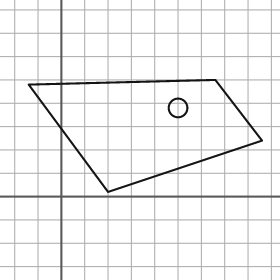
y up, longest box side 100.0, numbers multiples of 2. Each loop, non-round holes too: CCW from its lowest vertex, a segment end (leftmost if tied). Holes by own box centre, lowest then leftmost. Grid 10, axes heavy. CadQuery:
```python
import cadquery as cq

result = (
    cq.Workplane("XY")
    .moveTo(20.0, 2.0)
    .lineTo(86.0, 24.0)
    .lineTo(66.0, 50.0)
    .lineTo(-14.0, 48.0)
    .close()
    .moveTo(50.0, 38.0)
    .circle(4.0)
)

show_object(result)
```